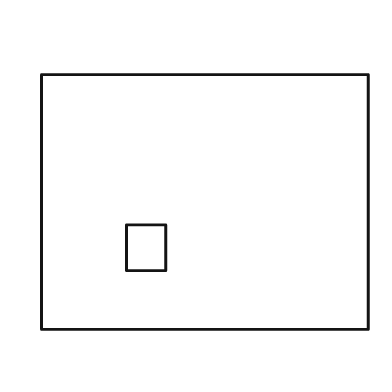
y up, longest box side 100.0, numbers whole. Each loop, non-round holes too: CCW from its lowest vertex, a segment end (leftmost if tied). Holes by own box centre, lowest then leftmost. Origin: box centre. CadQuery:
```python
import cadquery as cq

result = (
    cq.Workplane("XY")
    .moveTo(-50.0, -39.0)
    .lineTo(50.0, -39.0)
    .lineTo(50.0, 39.0)
    .lineTo(-50.0, 39.0)
    .close()
    .moveTo(-24.0, -21.0)
    .lineTo(-12.0, -21.0)
    .lineTo(-12.0, -7.0)
    .lineTo(-24.0, -7.0)
    .close()
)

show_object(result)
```